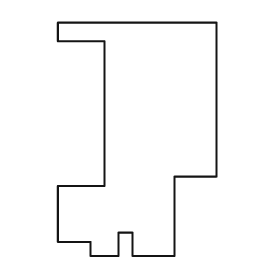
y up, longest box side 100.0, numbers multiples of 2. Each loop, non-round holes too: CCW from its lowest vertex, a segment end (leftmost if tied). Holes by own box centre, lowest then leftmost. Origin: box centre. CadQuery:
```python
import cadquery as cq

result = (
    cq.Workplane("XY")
    .moveTo(-20.0, -50.0)
    .lineTo(-8.0, -50.0)
    .lineTo(-8.0, -40.0)
    .lineTo(-2.0, -40.0)
    .lineTo(-2.0, -50.0)
    .lineTo(16.0, -50.0)
    .lineTo(16.0, -16.0)
    .lineTo(34.0, -16.0)
    .lineTo(34.0, 50.0)
    .lineTo(-34.0, 50.0)
    .lineTo(-34.0, 42.0)
    .lineTo(-14.0, 42.0)
    .lineTo(-14.0, -20.0)
    .lineTo(-34.0, -20.0)
    .lineTo(-34.0, -44.0)
    .lineTo(-20.0, -44.0)
    .close()
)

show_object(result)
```